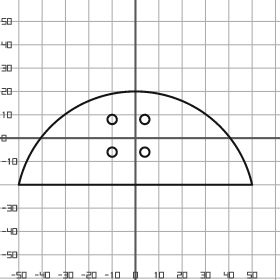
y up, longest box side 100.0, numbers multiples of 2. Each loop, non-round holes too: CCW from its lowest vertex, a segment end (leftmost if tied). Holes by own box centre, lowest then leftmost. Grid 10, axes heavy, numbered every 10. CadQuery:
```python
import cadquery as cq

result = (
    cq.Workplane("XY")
    .moveTo(-50.0, -20.0)
    .lineTo(50.0, -20.0)
    .threePointArc((0.0, 20.0), (-50.0, -20.0))
    .close()
    .moveTo(-10.0, -6.0)
    .circle(2.0)
    .moveTo(4.0, -6.0)
    .circle(2.0)
    .moveTo(-10.0, 8.0)
    .circle(2.0)
    .moveTo(4.0, 8.0)
    .circle(2.0)
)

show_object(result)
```